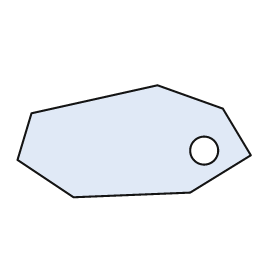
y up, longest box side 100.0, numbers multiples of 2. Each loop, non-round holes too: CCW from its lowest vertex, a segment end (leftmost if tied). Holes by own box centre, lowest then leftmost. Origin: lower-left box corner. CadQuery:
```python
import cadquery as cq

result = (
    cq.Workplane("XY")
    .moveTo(24.0, 0.0)
    .lineTo(74.0, 2.0)
    .lineTo(100.0, 18.0)
    .lineTo(88.0, 38.0)
    .lineTo(60.0, 48.0)
    .lineTo(6.0, 36.0)
    .lineTo(0.0, 16.0)
    .close()
    .moveTo(80.0, 20.0)
    .circle(6.0)
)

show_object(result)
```